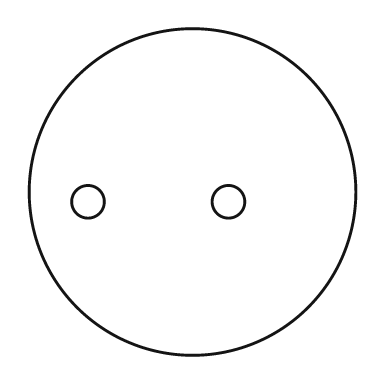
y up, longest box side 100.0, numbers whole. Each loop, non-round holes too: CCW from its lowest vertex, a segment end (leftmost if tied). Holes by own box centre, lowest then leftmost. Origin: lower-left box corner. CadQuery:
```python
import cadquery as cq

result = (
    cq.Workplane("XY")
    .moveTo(50.0, 50.0)
    .circle(50.0)
    .moveTo(18.0, 47.0)
    .circle(5.0)
    .moveTo(61.0, 47.0)
    .circle(5.0)
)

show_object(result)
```